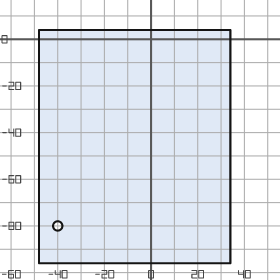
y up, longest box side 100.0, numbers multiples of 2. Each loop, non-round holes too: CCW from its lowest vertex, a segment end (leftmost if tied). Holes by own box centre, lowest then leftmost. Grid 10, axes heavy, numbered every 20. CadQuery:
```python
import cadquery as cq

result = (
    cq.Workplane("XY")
    .moveTo(-48.0, -96.0)
    .lineTo(34.0, -96.0)
    .lineTo(34.0, 4.0)
    .lineTo(-48.0, 4.0)
    .close()
    .moveTo(-40.0, -80.0)
    .circle(2.0)
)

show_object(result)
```